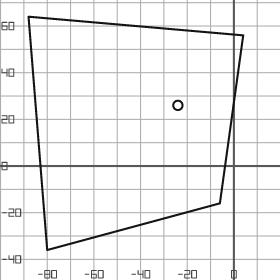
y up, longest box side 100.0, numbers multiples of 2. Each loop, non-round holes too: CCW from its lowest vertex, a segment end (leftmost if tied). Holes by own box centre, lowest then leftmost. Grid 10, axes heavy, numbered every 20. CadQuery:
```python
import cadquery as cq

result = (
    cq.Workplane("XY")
    .moveTo(-80.0, -36.0)
    .lineTo(-6.0, -16.0)
    .lineTo(4.0, 56.0)
    .lineTo(-88.0, 64.0)
    .close()
    .moveTo(-24.0, 26.0)
    .circle(2.0)
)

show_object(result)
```